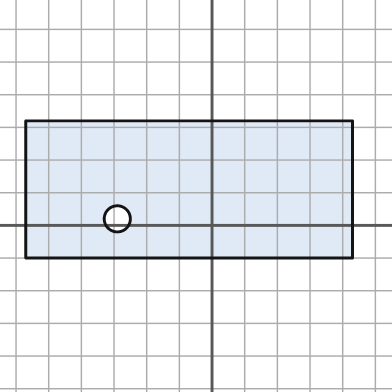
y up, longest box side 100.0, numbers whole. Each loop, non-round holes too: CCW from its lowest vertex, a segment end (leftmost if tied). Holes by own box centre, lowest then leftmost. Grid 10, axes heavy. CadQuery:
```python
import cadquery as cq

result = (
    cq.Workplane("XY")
    .moveTo(-57.0, -10.0)
    .lineTo(43.0, -10.0)
    .lineTo(43.0, 32.0)
    .lineTo(-57.0, 32.0)
    .close()
    .moveTo(-29.0, 2.0)
    .circle(4.0)
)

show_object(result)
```